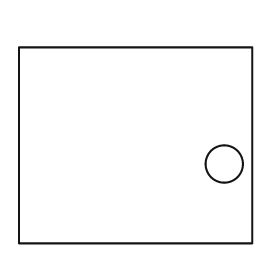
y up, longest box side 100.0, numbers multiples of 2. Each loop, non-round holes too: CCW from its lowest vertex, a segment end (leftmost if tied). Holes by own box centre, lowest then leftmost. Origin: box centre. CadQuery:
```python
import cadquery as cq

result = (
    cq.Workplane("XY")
    .moveTo(-50.0, -42.0)
    .lineTo(50.0, -42.0)
    .lineTo(50.0, 42.0)
    .lineTo(-50.0, 42.0)
    .close()
    .moveTo(38.0, -8.0)
    .circle(8.0)
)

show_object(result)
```